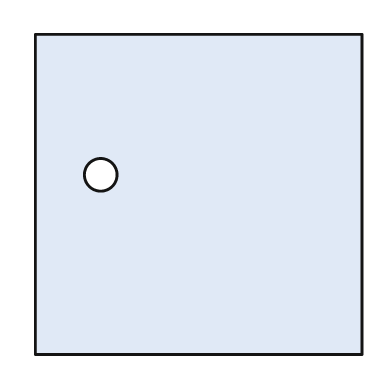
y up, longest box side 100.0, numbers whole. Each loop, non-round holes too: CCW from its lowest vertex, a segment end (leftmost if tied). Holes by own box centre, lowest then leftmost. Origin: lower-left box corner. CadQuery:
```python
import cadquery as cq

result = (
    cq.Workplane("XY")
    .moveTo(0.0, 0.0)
    .lineTo(100.0, 0.0)
    .lineTo(100.0, 98.0)
    .lineTo(0.0, 98.0)
    .close()
    .moveTo(20.0, 55.0)
    .circle(5.0)
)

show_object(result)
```